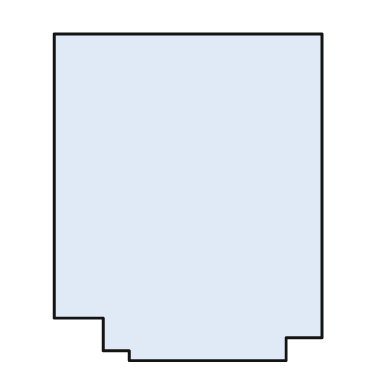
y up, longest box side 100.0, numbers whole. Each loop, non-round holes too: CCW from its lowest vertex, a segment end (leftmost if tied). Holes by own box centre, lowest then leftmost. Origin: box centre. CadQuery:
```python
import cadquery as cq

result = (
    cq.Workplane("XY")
    .moveTo(-18.0, -50.0)
    .lineTo(30.0, -50.0)
    .lineTo(30.0, -43.0)
    .lineTo(41.0, -43.0)
    .lineTo(41.0, 50.0)
    .lineTo(-41.0, 50.0)
    .lineTo(-41.0, -37.0)
    .lineTo(-26.0, -37.0)
    .lineTo(-26.0, -47.0)
    .lineTo(-18.0, -47.0)
    .close()
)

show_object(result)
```